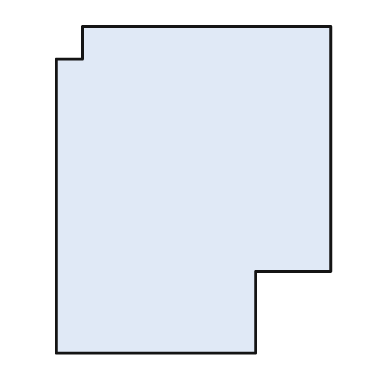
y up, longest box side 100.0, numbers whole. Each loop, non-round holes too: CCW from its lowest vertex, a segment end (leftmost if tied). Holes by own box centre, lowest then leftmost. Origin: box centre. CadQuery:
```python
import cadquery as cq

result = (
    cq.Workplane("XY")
    .moveTo(-42.0, -50.0)
    .lineTo(19.0, -50.0)
    .lineTo(19.0, -25.0)
    .lineTo(42.0, -25.0)
    .lineTo(42.0, 50.0)
    .lineTo(-34.0, 50.0)
    .lineTo(-34.0, 40.0)
    .lineTo(-42.0, 40.0)
    .close()
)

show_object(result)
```